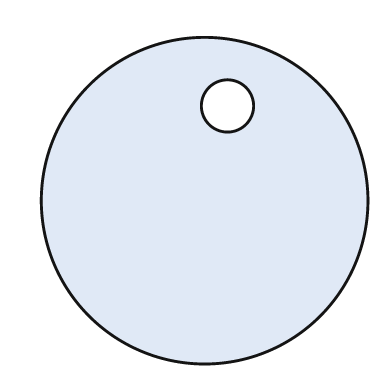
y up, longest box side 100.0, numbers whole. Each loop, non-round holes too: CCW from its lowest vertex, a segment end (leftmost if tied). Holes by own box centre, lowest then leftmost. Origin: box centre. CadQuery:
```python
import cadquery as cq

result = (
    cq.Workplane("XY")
    .moveTo(0.0, 0.0)
    .circle(50.0)
    .moveTo(7.0, 29.0)
    .circle(8.0)
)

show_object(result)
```